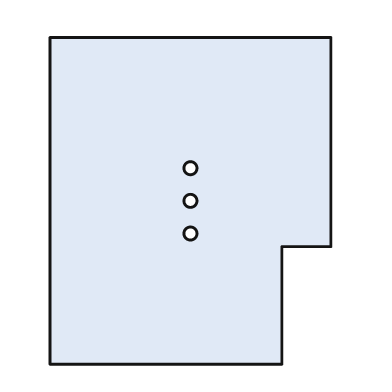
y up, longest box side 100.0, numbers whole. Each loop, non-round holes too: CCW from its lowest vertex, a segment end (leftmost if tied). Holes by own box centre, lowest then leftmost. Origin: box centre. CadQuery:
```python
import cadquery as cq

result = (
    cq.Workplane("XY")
    .moveTo(-43.0, -50.0)
    .lineTo(28.0, -50.0)
    .lineTo(28.0, -14.0)
    .lineTo(43.0, -14.0)
    .lineTo(43.0, 50.0)
    .lineTo(-43.0, 50.0)
    .close()
    .moveTo(0.0, -10.0)
    .circle(2.0)
    .moveTo(0.0, 0.0)
    .circle(2.0)
    .moveTo(0.0, 10.0)
    .circle(2.0)
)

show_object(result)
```